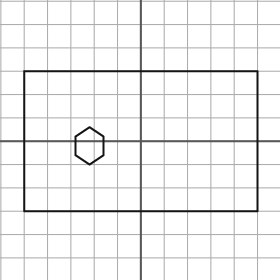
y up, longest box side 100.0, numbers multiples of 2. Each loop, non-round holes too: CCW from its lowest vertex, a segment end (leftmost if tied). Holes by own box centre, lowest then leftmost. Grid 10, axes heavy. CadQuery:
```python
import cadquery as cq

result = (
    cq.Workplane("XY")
    .moveTo(-50.0, -30.0)
    .lineTo(50.0, -30.0)
    .lineTo(50.0, 30.0)
    .lineTo(-50.0, 30.0)
    .close()
    .moveTo(-22.0, -10.0)
    .lineTo(-16.0, -6.0)
    .lineTo(-16.0, 2.0)
    .lineTo(-22.0, 6.0)
    .lineTo(-28.0, 2.0)
    .lineTo(-28.0, -6.0)
    .close()
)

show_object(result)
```